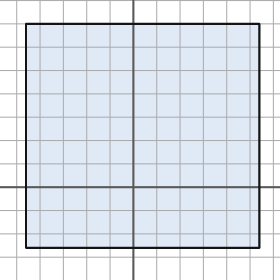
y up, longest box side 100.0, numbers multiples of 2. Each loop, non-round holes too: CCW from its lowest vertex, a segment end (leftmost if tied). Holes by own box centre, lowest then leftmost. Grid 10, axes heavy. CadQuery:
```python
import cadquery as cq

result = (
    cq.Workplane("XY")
    .moveTo(-46.0, -26.0)
    .lineTo(54.0, -26.0)
    .lineTo(54.0, 70.0)
    .lineTo(-46.0, 70.0)
    .close()
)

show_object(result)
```